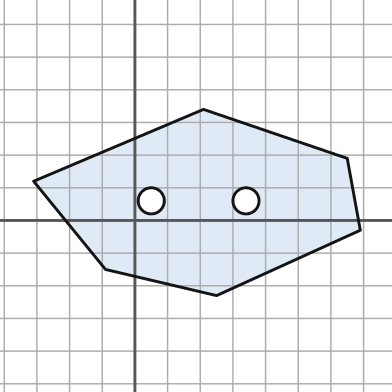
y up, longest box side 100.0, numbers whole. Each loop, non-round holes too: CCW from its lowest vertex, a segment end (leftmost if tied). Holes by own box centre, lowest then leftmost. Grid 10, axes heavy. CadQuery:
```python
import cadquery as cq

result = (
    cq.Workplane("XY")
    .moveTo(25.0, -23.0)
    .lineTo(69.0, -3.0)
    .lineTo(65.0, 19.0)
    .lineTo(21.0, 34.0)
    .lineTo(-31.0, 12.0)
    .lineTo(-9.0, -15.0)
    .close()
    .moveTo(5.0, 6.0)
    .circle(4.0)
    .moveTo(34.0, 6.0)
    .circle(4.0)
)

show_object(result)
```